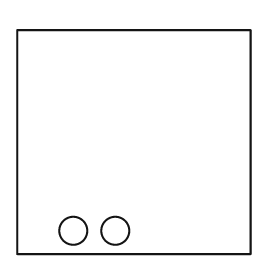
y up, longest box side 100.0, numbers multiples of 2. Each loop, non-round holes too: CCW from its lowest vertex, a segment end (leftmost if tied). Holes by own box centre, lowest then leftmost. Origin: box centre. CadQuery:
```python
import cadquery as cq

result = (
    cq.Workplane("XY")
    .moveTo(-50.0, -48.0)
    .lineTo(50.0, -48.0)
    .lineTo(50.0, 48.0)
    .lineTo(-50.0, 48.0)
    .close()
    .moveTo(-26.0, -38.0)
    .circle(6.0)
    .moveTo(-8.0, -38.0)
    .circle(6.0)
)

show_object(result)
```